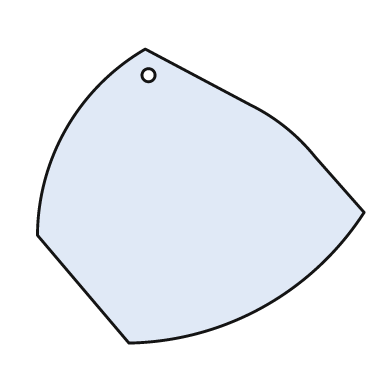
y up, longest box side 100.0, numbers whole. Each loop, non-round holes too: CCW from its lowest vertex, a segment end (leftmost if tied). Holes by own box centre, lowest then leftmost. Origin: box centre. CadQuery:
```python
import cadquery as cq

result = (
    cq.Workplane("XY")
    .moveTo(-22.0, -45.0)
    .threePointArc((19.0, -34.0), (50.0, -5.0))
    .lineTo(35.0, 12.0)
    .threePointArc((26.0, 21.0), (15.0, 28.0))
    .lineTo(-17.0, 45.0)
    .threePointArc((-41.0, 21.0), (-50.0, -12.0))
    .close()
    .moveTo(-16.0, 37.0)
    .circle(2.0)
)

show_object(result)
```